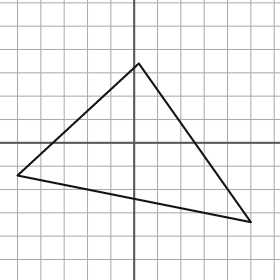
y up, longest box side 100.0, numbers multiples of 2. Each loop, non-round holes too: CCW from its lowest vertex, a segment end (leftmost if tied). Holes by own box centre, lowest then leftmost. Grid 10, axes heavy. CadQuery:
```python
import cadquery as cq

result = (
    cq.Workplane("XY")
    .moveTo(50.0, -34.0)
    .lineTo(2.0, 34.0)
    .lineTo(-50.0, -14.0)
    .close()
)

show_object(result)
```